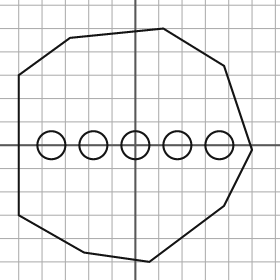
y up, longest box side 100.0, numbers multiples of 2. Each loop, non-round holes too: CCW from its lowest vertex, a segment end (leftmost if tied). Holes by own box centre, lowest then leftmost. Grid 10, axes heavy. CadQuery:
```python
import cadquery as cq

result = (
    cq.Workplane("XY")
    .moveTo(6.0, -50.0)
    .lineTo(38.0, -26.0)
    .lineTo(50.0, -2.0)
    .lineTo(38.0, 34.0)
    .lineTo(12.0, 50.0)
    .lineTo(-28.0, 46.0)
    .lineTo(-50.0, 30.0)
    .lineTo(-50.0, -30.0)
    .lineTo(-22.0, -46.0)
    .close()
    .moveTo(-36.0, 0.0)
    .circle(6.0)
    .moveTo(-18.0, 0.0)
    .circle(6.0)
    .moveTo(0.0, 0.0)
    .circle(6.0)
    .moveTo(18.0, 0.0)
    .circle(6.0)
    .moveTo(36.0, 0.0)
    .circle(6.0)
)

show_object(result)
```